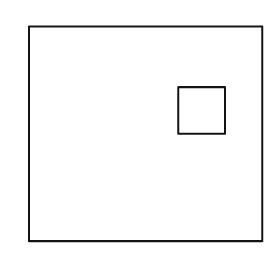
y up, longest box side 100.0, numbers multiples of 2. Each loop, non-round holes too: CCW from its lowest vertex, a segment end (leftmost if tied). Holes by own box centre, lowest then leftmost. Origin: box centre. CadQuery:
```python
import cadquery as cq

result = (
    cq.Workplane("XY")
    .moveTo(-50.0, -46.0)
    .lineTo(50.0, -46.0)
    .lineTo(50.0, 46.0)
    .lineTo(-50.0, 46.0)
    .close()
    .moveTo(14.0, 0.0)
    .lineTo(34.0, 0.0)
    .lineTo(34.0, 20.0)
    .lineTo(14.0, 20.0)
    .close()
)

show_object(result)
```